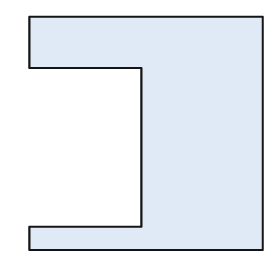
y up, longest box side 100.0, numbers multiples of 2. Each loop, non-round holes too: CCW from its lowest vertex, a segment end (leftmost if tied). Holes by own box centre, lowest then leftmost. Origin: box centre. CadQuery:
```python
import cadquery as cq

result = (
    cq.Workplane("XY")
    .moveTo(-50.0, -50.0)
    .lineTo(50.0, -50.0)
    .lineTo(50.0, 50.0)
    .lineTo(-50.0, 50.0)
    .lineTo(-50.0, 28.0)
    .lineTo(-2.0, 28.0)
    .lineTo(-2.0, -40.0)
    .lineTo(-50.0, -40.0)
    .close()
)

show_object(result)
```